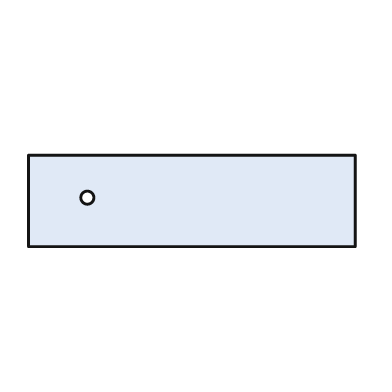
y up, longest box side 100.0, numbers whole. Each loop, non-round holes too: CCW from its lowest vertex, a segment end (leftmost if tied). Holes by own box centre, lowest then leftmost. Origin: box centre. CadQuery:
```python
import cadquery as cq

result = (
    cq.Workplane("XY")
    .moveTo(-50.0, -14.0)
    .lineTo(50.0, -14.0)
    .lineTo(50.0, 14.0)
    .lineTo(-50.0, 14.0)
    .close()
    .moveTo(-32.0, 1.0)
    .circle(2.0)
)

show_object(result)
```